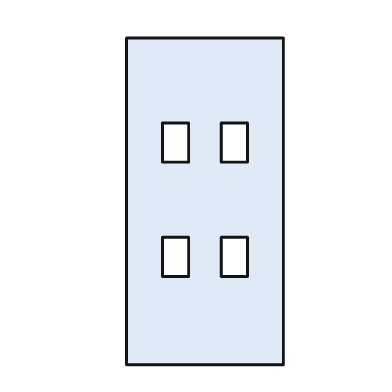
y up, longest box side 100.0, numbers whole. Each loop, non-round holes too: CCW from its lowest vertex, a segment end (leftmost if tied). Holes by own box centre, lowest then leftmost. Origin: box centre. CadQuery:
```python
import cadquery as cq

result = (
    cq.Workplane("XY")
    .moveTo(-24.0, -50.0)
    .lineTo(24.0, -50.0)
    .lineTo(24.0, 50.0)
    .lineTo(-24.0, 50.0)
    .close()
    .moveTo(-13.0, -23.0)
    .lineTo(-5.0, -23.0)
    .lineTo(-5.0, -11.0)
    .lineTo(-13.0, -11.0)
    .close()
    .moveTo(5.0, -23.0)
    .lineTo(13.0, -23.0)
    .lineTo(13.0, -11.0)
    .lineTo(5.0, -11.0)
    .close()
    .moveTo(-13.0, 12.0)
    .lineTo(-5.0, 12.0)
    .lineTo(-5.0, 24.0)
    .lineTo(-13.0, 24.0)
    .close()
    .moveTo(5.0, 12.0)
    .lineTo(13.0, 12.0)
    .lineTo(13.0, 24.0)
    .lineTo(5.0, 24.0)
    .close()
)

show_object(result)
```